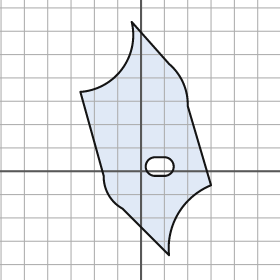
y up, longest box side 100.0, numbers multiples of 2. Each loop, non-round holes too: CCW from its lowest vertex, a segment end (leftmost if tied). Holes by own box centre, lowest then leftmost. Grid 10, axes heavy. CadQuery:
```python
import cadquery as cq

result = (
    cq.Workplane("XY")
    .moveTo(12.0, -36.0)
    .threePointArc((16.0, -18.0), (30.0, -6.0))
    .lineTo(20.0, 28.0)
    .threePointArc((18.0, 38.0), (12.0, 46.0))
    .lineTo(-4.0, 64.0)
    .threePointArc((-8.0, 44.0), (-26.0, 34.0))
    .lineTo(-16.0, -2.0)
    .threePointArc((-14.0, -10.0), (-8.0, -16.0))
    .close()
    .moveTo(6.0, -2.0)
    .lineTo(10.0, -2.0)
    .threePointArc((14.0, 2.0), (10.0, 6.0))
    .lineTo(6.0, 6.0)
    .threePointArc((2.0, 2.0), (6.0, -2.0))
    .close()
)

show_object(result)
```